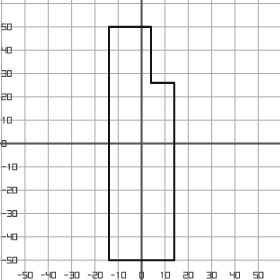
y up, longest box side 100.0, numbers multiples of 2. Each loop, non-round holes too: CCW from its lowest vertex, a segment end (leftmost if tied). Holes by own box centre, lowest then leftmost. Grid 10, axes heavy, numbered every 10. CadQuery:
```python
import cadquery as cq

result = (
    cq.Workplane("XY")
    .moveTo(-14.0, -50.0)
    .lineTo(14.0, -50.0)
    .lineTo(14.0, 26.0)
    .lineTo(4.0, 26.0)
    .lineTo(4.0, 50.0)
    .lineTo(-14.0, 50.0)
    .close()
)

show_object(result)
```